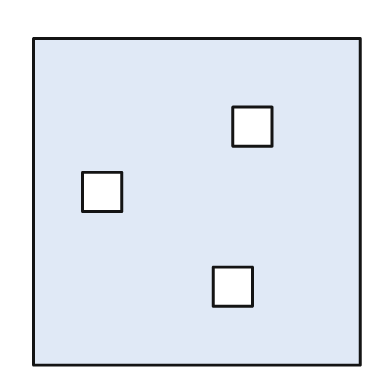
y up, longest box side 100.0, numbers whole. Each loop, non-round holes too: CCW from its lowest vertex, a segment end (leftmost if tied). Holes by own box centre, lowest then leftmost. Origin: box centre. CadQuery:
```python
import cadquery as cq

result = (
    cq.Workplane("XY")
    .moveTo(-50.0, -50.0)
    .lineTo(50.0, -50.0)
    .lineTo(50.0, 50.0)
    .lineTo(-50.0, 50.0)
    .close()
    .moveTo(5.0, -32.0)
    .lineTo(17.0, -32.0)
    .lineTo(17.0, -20.0)
    .lineTo(5.0, -20.0)
    .close()
    .moveTo(-35.0, -3.0)
    .lineTo(-23.0, -3.0)
    .lineTo(-23.0, 9.0)
    .lineTo(-35.0, 9.0)
    .close()
    .moveTo(11.0, 17.0)
    .lineTo(23.0, 17.0)
    .lineTo(23.0, 29.0)
    .lineTo(11.0, 29.0)
    .close()
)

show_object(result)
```